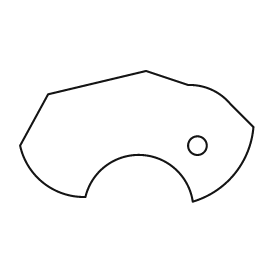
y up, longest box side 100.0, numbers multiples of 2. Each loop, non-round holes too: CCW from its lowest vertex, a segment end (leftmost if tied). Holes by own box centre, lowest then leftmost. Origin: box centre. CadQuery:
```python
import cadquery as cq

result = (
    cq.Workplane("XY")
    .moveTo(24.0, -28.0)
    .threePointArc((42.0, -16.0), (50.0, 4.0))
    .lineTo(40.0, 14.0)
    .threePointArc((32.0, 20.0), (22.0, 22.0))
    .lineTo(4.0, 28.0)
    .lineTo(-38.0, 18.0)
    .lineTo(-50.0, -4.0)
    .threePointArc((-40.0, -20.0), (-22.0, -26.0))
    .threePointArc((2.0, -8.0), (24.0, -28.0))
    .close()
    .moveTo(26.0, -4.0)
    .circle(4.0)
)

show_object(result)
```